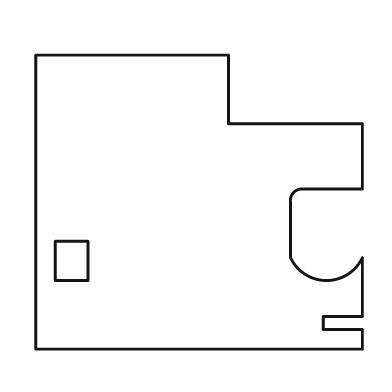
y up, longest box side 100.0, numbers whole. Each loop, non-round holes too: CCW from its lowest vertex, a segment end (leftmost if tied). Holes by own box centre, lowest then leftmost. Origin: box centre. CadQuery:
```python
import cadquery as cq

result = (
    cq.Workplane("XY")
    .moveTo(-50.0, -45.0)
    .lineTo(50.0, -45.0)
    .lineTo(50.0, -39.0)
    .lineTo(38.0, -39.0)
    .lineTo(38.0, -35.0)
    .lineTo(50.0, -35.0)
    .lineTo(50.0, -17.0)
    .threePointArc((39.0, -24.0), (28.0, -17.0))
    .lineTo(28.0, 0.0)
    .threePointArc((29.0, 3.0), (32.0, 4.0))
    .lineTo(50.0, 4.0)
    .lineTo(50.0, 24.0)
    .lineTo(9.0, 24.0)
    .lineTo(9.0, 45.0)
    .lineTo(-50.0, 45.0)
    .close()
    .moveTo(-44.0, -24.0)
    .lineTo(-34.0, -24.0)
    .lineTo(-34.0, -12.0)
    .lineTo(-44.0, -12.0)
    .close()
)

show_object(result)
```